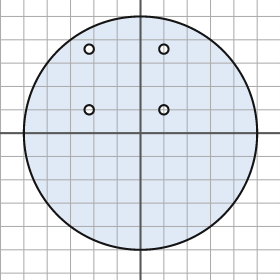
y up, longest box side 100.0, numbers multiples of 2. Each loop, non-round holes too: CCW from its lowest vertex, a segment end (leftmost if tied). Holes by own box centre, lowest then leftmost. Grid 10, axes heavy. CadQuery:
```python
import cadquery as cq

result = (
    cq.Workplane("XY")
    .moveTo(0.0, 0.0)
    .circle(50.0)
    .moveTo(-22.0, 10.0)
    .circle(2.0)
    .moveTo(10.0, 10.0)
    .circle(2.0)
    .moveTo(-22.0, 36.0)
    .circle(2.0)
    .moveTo(10.0, 36.0)
    .circle(2.0)
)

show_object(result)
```